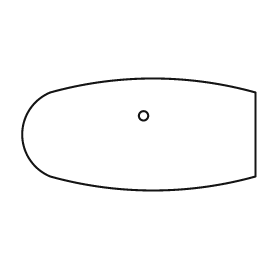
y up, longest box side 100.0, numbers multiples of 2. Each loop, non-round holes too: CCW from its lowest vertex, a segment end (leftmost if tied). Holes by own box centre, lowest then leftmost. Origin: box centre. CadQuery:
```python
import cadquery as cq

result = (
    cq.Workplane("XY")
    .moveTo(-38.0, -18.0)
    .threePointArc((6.0, -24.0), (50.0, -18.0))
    .lineTo(50.0, 18.0)
    .threePointArc((6.0, 24.0), (-38.0, 18.0))
    .threePointArc((-50.0, 0.0), (-38.0, -18.0))
    .close()
    .moveTo(2.0, 8.0)
    .circle(2.0)
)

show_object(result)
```